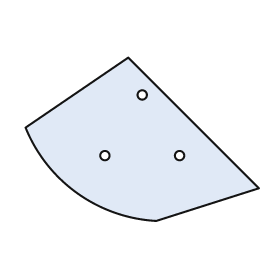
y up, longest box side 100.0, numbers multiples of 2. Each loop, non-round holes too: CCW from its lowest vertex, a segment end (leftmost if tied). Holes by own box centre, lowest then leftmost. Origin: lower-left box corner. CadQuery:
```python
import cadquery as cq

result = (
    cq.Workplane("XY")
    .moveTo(56.0, 0.0)
    .lineTo(100.0, 14.0)
    .lineTo(44.0, 70.0)
    .lineTo(0.0, 40.0)
    .threePointArc((22.0, 12.0), (56.0, 0.0))
    .close()
    .moveTo(34.0, 28.0)
    .circle(2.0)
    .moveTo(66.0, 28.0)
    .circle(2.0)
    .moveTo(50.0, 54.0)
    .circle(2.0)
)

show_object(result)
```